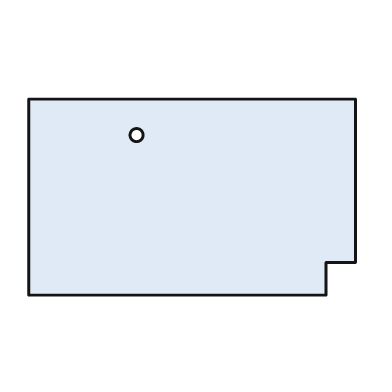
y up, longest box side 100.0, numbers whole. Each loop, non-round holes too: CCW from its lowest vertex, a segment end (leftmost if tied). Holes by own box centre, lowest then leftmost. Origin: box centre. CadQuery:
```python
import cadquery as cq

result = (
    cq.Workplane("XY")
    .moveTo(-50.0, -30.0)
    .lineTo(41.0, -30.0)
    .lineTo(41.0, -20.0)
    .lineTo(50.0, -20.0)
    .lineTo(50.0, 30.0)
    .lineTo(-50.0, 30.0)
    .close()
    .moveTo(-17.0, 19.0)
    .circle(2.0)
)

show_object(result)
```